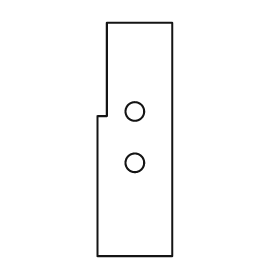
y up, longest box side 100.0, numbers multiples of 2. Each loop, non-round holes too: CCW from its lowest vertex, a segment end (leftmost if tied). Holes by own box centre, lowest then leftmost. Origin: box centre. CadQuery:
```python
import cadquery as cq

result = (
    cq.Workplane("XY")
    .moveTo(-16.0, -50.0)
    .lineTo(16.0, -50.0)
    .lineTo(16.0, 50.0)
    .lineTo(-12.0, 50.0)
    .lineTo(-12.0, 10.0)
    .lineTo(-16.0, 10.0)
    .close()
    .moveTo(0.0, -10.0)
    .circle(4.0)
    .moveTo(0.0, 12.0)
    .circle(4.0)
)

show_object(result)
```